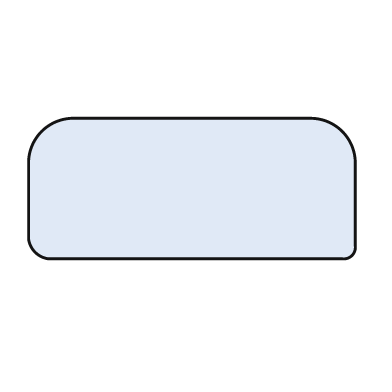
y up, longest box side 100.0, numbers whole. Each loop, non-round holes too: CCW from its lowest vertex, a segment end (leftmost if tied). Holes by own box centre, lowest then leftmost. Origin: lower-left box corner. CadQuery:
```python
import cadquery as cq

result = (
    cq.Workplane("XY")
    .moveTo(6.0, 0.0)
    .lineTo(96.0, 0.0)
    .threePointArc((99.0, 1.0), (100.0, 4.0))
    .lineTo(100.0, 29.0)
    .threePointArc((96.0, 39.0), (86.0, 43.0))
    .lineTo(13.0, 43.0)
    .threePointArc((4.0, 39.0), (0.0, 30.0))
    .lineTo(0.0, 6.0)
    .threePointArc((2.0, 2.0), (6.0, 0.0))
    .close()
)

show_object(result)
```